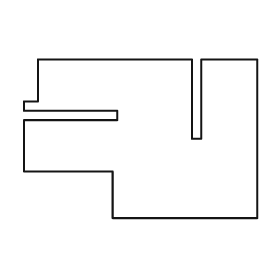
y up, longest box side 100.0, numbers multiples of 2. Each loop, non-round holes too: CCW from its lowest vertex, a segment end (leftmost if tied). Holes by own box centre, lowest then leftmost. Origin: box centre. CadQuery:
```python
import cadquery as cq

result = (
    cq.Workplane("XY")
    .moveTo(-12.0, -34.0)
    .lineTo(50.0, -34.0)
    .lineTo(50.0, 34.0)
    .lineTo(26.0, 34.0)
    .lineTo(26.0, 0.0)
    .lineTo(22.0, 0.0)
    .lineTo(22.0, 34.0)
    .lineTo(-44.0, 34.0)
    .lineTo(-44.0, 16.0)
    .lineTo(-50.0, 16.0)
    .lineTo(-50.0, 12.0)
    .lineTo(-10.0, 12.0)
    .lineTo(-10.0, 8.0)
    .lineTo(-50.0, 8.0)
    .lineTo(-50.0, -14.0)
    .lineTo(-12.0, -14.0)
    .close()
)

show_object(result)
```